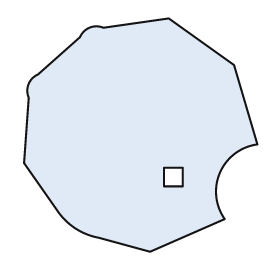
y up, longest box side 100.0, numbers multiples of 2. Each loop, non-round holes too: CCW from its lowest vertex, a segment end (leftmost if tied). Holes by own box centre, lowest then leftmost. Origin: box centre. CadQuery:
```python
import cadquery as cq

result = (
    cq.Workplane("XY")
    .moveTo(4.0, -50.0)
    .lineTo(36.0, -36.0)
    .threePointArc((34.0, -16.0), (50.0, -4.0))
    .lineTo(40.0, 30.0)
    .lineTo(12.0, 50.0)
    .lineTo(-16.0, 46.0)
    .threePointArc((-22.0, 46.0), (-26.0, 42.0))
    .lineTo(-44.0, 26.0)
    .threePointArc((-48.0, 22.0), (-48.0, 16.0))
    .lineTo(-50.0, -12.0)
    .lineTo(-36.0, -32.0)
    .threePointArc((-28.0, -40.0), (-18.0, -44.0))
    .close()
    .moveTo(10.0, -22.0)
    .lineTo(18.0, -22.0)
    .lineTo(18.0, -14.0)
    .lineTo(10.0, -14.0)
    .close()
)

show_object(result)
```